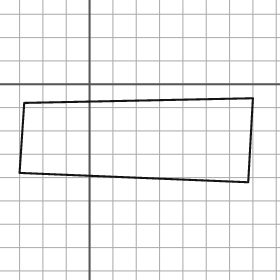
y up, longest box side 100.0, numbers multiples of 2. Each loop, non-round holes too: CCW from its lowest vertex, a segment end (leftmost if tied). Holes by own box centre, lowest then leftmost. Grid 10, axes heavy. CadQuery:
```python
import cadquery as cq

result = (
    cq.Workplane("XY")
    .moveTo(68.0, -42.0)
    .lineTo(70.0, -6.0)
    .lineTo(-28.0, -8.0)
    .lineTo(-30.0, -38.0)
    .close()
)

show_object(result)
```